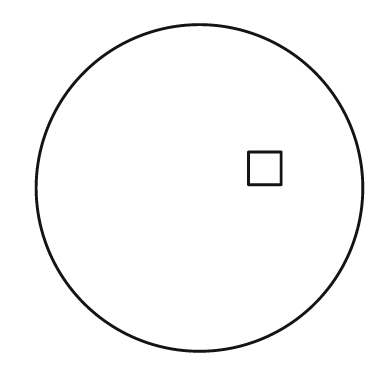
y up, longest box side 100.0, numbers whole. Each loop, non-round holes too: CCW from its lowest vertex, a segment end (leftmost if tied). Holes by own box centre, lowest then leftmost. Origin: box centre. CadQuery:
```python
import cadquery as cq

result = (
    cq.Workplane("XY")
    .moveTo(0.0, 0.0)
    .circle(50.0)
    .moveTo(15.0, 1.0)
    .lineTo(25.0, 1.0)
    .lineTo(25.0, 11.0)
    .lineTo(15.0, 11.0)
    .close()
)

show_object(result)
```